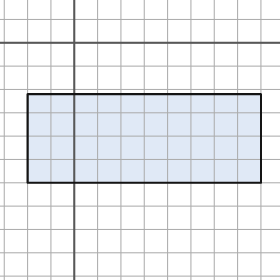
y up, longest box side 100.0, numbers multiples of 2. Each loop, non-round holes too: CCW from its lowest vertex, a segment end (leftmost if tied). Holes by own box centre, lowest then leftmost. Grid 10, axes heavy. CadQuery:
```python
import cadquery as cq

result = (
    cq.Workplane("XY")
    .moveTo(-20.0, -60.0)
    .lineTo(80.0, -60.0)
    .lineTo(80.0, -22.0)
    .lineTo(-20.0, -22.0)
    .close()
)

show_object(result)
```